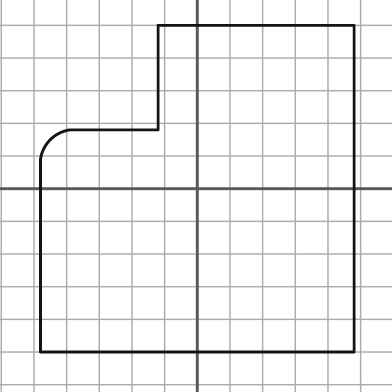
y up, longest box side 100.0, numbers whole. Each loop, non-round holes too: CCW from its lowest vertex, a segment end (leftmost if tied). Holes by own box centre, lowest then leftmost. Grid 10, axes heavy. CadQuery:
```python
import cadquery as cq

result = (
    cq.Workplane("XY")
    .moveTo(-48.0, -50.0)
    .lineTo(48.0, -50.0)
    .lineTo(48.0, 50.0)
    .lineTo(-12.0, 50.0)
    .lineTo(-12.0, 18.0)
    .lineTo(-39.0, 18.0)
    .threePointArc((-45.0, 15.0), (-48.0, 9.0))
    .close()
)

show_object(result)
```